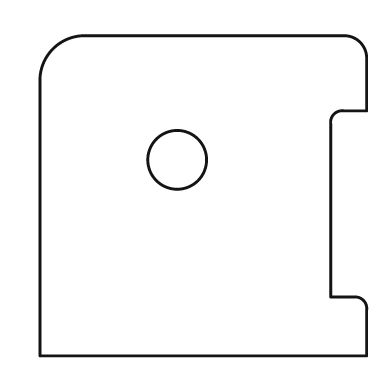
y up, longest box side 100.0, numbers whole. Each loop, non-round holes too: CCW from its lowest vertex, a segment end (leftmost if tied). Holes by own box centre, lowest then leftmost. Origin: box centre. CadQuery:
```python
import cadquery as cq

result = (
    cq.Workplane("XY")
    .moveTo(-50.0, -49.0)
    .lineTo(50.0, -49.0)
    .lineTo(50.0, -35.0)
    .threePointArc((49.0, -32.0), (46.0, -31.0))
    .lineTo(39.0, -31.0)
    .lineTo(39.0, 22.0)
    .threePointArc((40.0, 25.0), (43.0, 26.0))
    .lineTo(50.0, 26.0)
    .lineTo(50.0, 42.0)
    .threePointArc((48.0, 47.0), (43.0, 49.0))
    .lineTo(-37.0, 49.0)
    .threePointArc((-46.0, 45.0), (-50.0, 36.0))
    .close()
    .moveTo(-8.0, 11.0)
    .circle(9.0)
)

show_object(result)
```